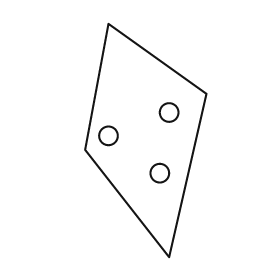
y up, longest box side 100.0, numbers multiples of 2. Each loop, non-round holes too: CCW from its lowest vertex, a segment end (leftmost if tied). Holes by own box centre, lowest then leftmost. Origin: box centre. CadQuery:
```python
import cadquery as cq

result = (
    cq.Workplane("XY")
    .moveTo(10.0, -50.0)
    .lineTo(26.0, 20.0)
    .lineTo(-16.0, 50.0)
    .lineTo(-26.0, -4.0)
    .close()
    .moveTo(6.0, -14.0)
    .circle(4.0)
    .moveTo(-16.0, 2.0)
    .circle(4.0)
    .moveTo(10.0, 12.0)
    .circle(4.0)
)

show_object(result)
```